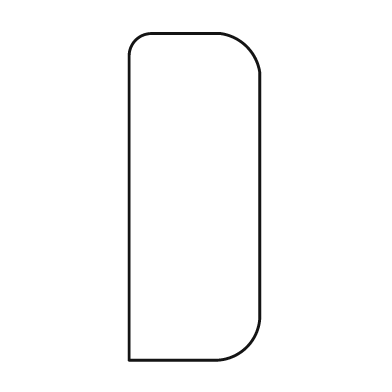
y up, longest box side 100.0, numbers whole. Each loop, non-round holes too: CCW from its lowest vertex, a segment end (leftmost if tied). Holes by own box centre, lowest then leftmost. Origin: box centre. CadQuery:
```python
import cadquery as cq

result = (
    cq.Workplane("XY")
    .moveTo(-20.0, -50.0)
    .lineTo(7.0, -50.0)
    .threePointArc((16.0, -46.0), (20.0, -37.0))
    .lineTo(20.0, 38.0)
    .threePointArc((16.0, 46.0), (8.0, 50.0))
    .lineTo(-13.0, 50.0)
    .threePointArc((-18.0, 48.0), (-20.0, 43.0))
    .close()
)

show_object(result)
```